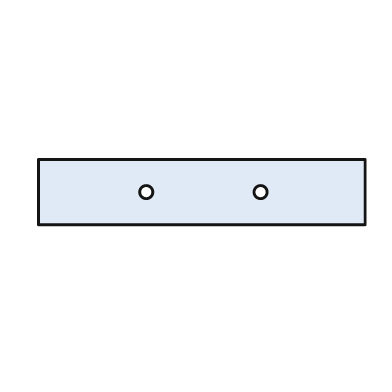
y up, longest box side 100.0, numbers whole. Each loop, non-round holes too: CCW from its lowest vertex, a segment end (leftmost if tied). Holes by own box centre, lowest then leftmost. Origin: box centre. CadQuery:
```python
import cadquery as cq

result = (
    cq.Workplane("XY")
    .moveTo(-50.0, -10.0)
    .lineTo(50.0, -10.0)
    .lineTo(50.0, 10.0)
    .lineTo(-50.0, 10.0)
    .close()
    .moveTo(-17.0, 0.0)
    .circle(2.0)
    .moveTo(18.0, 0.0)
    .circle(2.0)
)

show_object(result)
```